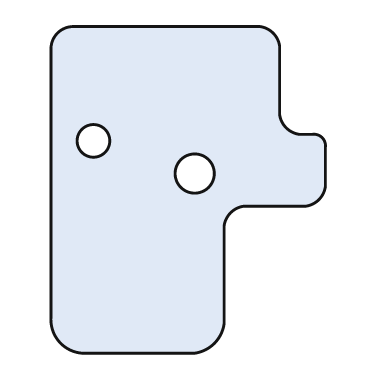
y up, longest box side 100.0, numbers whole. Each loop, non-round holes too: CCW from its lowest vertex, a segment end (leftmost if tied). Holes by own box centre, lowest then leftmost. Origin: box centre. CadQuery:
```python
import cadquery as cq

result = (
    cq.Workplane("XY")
    .moveTo(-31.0, -50.0)
    .lineTo(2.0, -50.0)
    .threePointArc((8.0, -47.0), (11.0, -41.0))
    .lineTo(11.0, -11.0)
    .threePointArc((13.0, -7.0), (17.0, -5.0))
    .lineTo(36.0, -5.0)
    .threePointArc((40.0, -3.0), (42.0, 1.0))
    .lineTo(42.0, 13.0)
    .threePointArc((41.0, 16.0), (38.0, 17.0))
    .lineTo(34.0, 17.0)
    .threePointArc((30.0, 19.0), (28.0, 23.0))
    .lineTo(28.0, 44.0)
    .threePointArc((26.0, 48.0), (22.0, 50.0))
    .lineTo(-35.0, 50.0)
    .threePointArc((-40.0, 48.0), (-42.0, 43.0))
    .lineTo(-42.0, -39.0)
    .threePointArc((-39.0, -47.0), (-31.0, -50.0))
    .close()
    .moveTo(2.0, 5.0)
    .circle(6.0)
    .moveTo(-29.0, 15.0)
    .circle(5.0)
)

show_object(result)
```